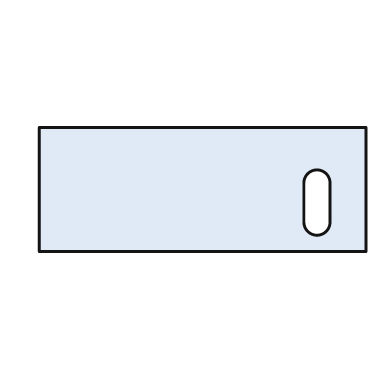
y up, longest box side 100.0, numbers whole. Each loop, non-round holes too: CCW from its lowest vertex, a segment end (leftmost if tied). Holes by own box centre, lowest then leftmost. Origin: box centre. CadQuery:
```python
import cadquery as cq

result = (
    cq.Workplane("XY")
    .moveTo(-50.0, -19.0)
    .lineTo(50.0, -19.0)
    .lineTo(50.0, 19.0)
    .lineTo(-50.0, 19.0)
    .close()
    .moveTo(31.0, -10.0)
    .threePointArc((35.0, -14.0), (39.0, -10.0))
    .lineTo(39.0, 2.0)
    .threePointArc((35.0, 6.0), (31.0, 2.0))
    .close()
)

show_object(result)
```